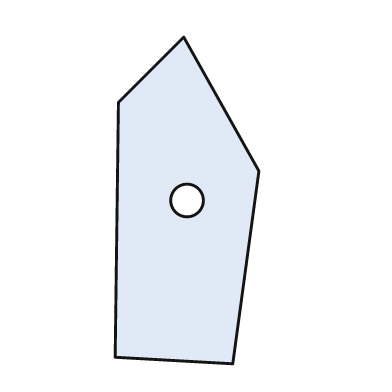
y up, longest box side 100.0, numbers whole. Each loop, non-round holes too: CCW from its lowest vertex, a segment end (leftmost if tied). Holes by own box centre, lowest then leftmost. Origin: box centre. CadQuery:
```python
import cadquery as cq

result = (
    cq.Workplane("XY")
    .moveTo(14.0, -50.0)
    .lineTo(22.0, 9.0)
    .lineTo(-1.0, 50.0)
    .lineTo(-21.0, 30.0)
    .lineTo(-22.0, -48.0)
    .close()
    .moveTo(0.0, 0.0)
    .circle(5.0)
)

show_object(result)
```